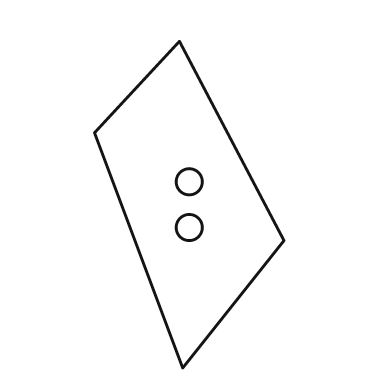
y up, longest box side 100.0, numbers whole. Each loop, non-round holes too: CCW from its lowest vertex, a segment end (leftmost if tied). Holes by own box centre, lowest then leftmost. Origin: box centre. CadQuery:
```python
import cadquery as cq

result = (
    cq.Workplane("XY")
    .moveTo(-2.0, -50.0)
    .lineTo(29.0, -11.0)
    .lineTo(-3.0, 50.0)
    .lineTo(-29.0, 22.0)
    .close()
    .moveTo(0.0, -7.0)
    .circle(4.0)
    .moveTo(0.0, 7.0)
    .circle(4.0)
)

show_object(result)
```